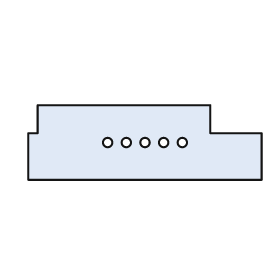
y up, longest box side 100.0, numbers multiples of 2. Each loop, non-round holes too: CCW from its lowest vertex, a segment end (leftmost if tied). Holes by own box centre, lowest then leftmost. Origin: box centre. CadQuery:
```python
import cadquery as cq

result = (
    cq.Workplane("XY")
    .moveTo(-50.0, -16.0)
    .lineTo(50.0, -16.0)
    .lineTo(50.0, 4.0)
    .lineTo(28.0, 4.0)
    .lineTo(28.0, 16.0)
    .lineTo(-46.0, 16.0)
    .lineTo(-46.0, 4.0)
    .lineTo(-50.0, 4.0)
    .close()
    .moveTo(-16.0, 0.0)
    .circle(2.0)
    .moveTo(-8.0, 0.0)
    .circle(2.0)
    .moveTo(0.0, 0.0)
    .circle(2.0)
    .moveTo(8.0, 0.0)
    .circle(2.0)
    .moveTo(16.0, 0.0)
    .circle(2.0)
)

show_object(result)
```